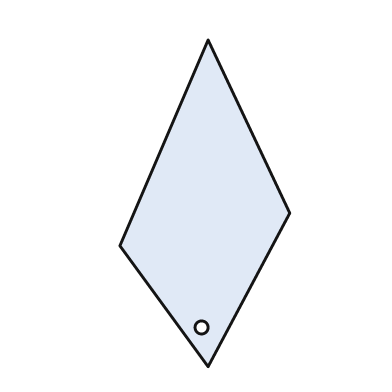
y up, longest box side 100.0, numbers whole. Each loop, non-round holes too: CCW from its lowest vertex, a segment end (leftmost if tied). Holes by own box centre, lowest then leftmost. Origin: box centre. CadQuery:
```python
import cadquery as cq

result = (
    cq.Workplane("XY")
    .moveTo(1.0, -50.0)
    .lineTo(26.0, -3.0)
    .lineTo(1.0, 50.0)
    .lineTo(-26.0, -13.0)
    .close()
    .moveTo(-1.0, -38.0)
    .circle(2.0)
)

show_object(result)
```